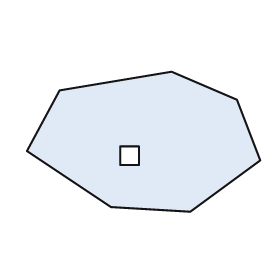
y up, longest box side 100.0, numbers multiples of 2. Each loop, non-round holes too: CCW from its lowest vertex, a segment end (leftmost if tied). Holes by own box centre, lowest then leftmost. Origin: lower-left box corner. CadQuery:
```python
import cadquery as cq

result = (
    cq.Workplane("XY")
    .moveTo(70.0, 0.0)
    .lineTo(100.0, 22.0)
    .lineTo(90.0, 48.0)
    .lineTo(62.0, 60.0)
    .lineTo(14.0, 52.0)
    .lineTo(0.0, 26.0)
    .lineTo(36.0, 2.0)
    .close()
    .moveTo(40.0, 20.0)
    .lineTo(48.0, 20.0)
    .lineTo(48.0, 28.0)
    .lineTo(40.0, 28.0)
    .close()
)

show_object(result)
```